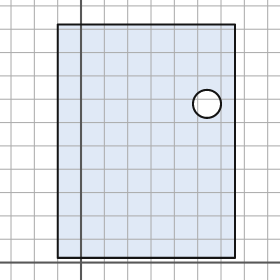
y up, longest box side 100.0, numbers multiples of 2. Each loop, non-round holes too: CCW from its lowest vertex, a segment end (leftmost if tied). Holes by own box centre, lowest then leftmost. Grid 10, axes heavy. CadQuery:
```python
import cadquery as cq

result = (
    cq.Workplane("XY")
    .moveTo(-10.0, 2.0)
    .lineTo(66.0, 2.0)
    .lineTo(66.0, 102.0)
    .lineTo(-10.0, 102.0)
    .close()
    .moveTo(54.0, 68.0)
    .circle(6.0)
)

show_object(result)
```